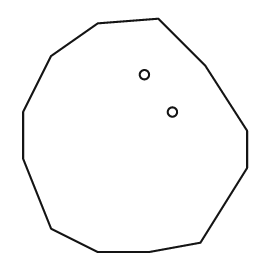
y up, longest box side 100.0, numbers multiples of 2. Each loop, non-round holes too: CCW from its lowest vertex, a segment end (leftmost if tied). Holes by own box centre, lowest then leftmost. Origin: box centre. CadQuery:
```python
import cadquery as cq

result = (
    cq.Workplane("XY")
    .moveTo(-16.0, -50.0)
    .lineTo(6.0, -50.0)
    .lineTo(28.0, -46.0)
    .lineTo(48.0, -14.0)
    .lineTo(48.0, 2.0)
    .lineTo(30.0, 30.0)
    .lineTo(10.0, 50.0)
    .lineTo(-16.0, 48.0)
    .lineTo(-36.0, 34.0)
    .lineTo(-48.0, 10.0)
    .lineTo(-48.0, -10.0)
    .lineTo(-36.0, -40.0)
    .close()
    .moveTo(16.0, 10.0)
    .circle(2.0)
    .moveTo(4.0, 26.0)
    .circle(2.0)
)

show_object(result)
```